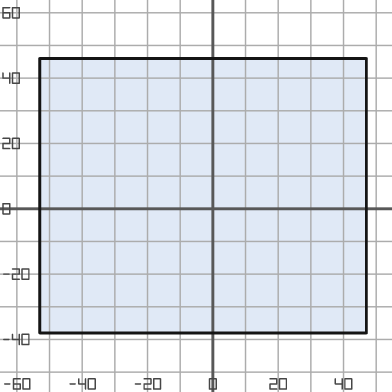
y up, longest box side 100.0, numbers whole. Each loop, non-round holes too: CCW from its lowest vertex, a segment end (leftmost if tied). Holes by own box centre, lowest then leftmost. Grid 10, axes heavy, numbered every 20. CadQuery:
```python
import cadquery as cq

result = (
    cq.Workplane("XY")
    .moveTo(-53.0, -38.0)
    .lineTo(47.0, -38.0)
    .lineTo(47.0, 46.0)
    .lineTo(-53.0, 46.0)
    .close()
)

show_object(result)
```